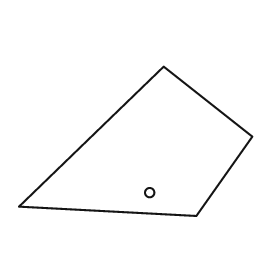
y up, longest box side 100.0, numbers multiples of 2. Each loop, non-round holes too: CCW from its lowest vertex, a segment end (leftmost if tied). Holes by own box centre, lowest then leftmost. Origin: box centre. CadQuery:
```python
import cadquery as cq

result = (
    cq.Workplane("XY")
    .moveTo(26.0, -32.0)
    .lineTo(50.0, 2.0)
    .lineTo(12.0, 32.0)
    .lineTo(-50.0, -28.0)
    .close()
    .moveTo(6.0, -22.0)
    .circle(2.0)
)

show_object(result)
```